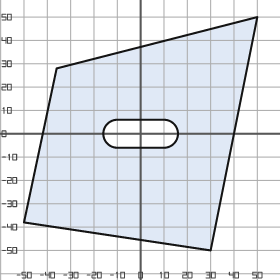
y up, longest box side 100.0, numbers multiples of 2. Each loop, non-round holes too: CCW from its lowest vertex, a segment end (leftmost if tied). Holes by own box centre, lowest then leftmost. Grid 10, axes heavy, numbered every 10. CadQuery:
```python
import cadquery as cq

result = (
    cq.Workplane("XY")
    .moveTo(30.0, -50.0)
    .lineTo(50.0, 50.0)
    .lineTo(-36.0, 28.0)
    .lineTo(-50.0, -38.0)
    .close()
    .moveTo(-10.0, -6.0)
    .lineTo(10.0, -6.0)
    .threePointArc((16.0, 0.0), (10.0, 6.0))
    .lineTo(-10.0, 6.0)
    .threePointArc((-16.0, 0.0), (-10.0, -6.0))
    .close()
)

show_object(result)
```